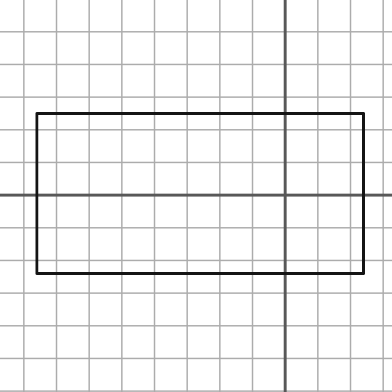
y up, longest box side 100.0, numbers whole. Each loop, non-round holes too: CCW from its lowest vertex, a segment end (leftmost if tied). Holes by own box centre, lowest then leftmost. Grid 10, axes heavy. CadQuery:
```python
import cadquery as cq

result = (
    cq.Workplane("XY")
    .moveTo(-76.0, -24.0)
    .lineTo(24.0, -24.0)
    .lineTo(24.0, 25.0)
    .lineTo(-76.0, 25.0)
    .close()
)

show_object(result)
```